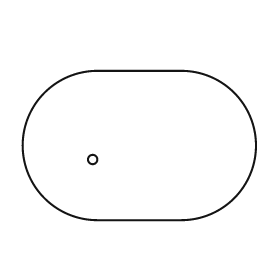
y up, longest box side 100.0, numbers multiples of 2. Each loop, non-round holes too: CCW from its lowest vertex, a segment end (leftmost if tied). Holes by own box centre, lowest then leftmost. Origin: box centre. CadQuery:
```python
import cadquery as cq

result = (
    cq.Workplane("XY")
    .moveTo(-18.0, -32.0)
    .lineTo(18.0, -32.0)
    .threePointArc((50.0, 0.0), (18.0, 32.0))
    .lineTo(-18.0, 32.0)
    .threePointArc((-50.0, 0.0), (-18.0, -32.0))
    .close()
    .moveTo(-20.0, -6.0)
    .circle(2.0)
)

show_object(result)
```